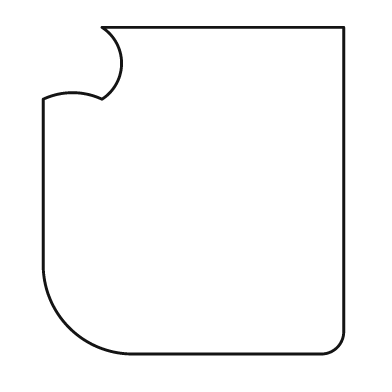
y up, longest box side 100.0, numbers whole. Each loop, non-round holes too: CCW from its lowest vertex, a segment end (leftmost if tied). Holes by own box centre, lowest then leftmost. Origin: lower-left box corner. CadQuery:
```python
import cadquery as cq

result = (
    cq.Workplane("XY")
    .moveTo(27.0, 0.0)
    .lineTo(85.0, 0.0)
    .threePointArc((90.0, 2.0), (92.0, 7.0))
    .lineTo(92.0, 100.0)
    .lineTo(18.0, 100.0)
    .threePointArc((24.0, 89.0), (18.0, 78.0))
    .threePointArc((9.0, 80.0), (0.0, 78.0))
    .lineTo(0.0, 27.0)
    .threePointArc((8.0, 8.0), (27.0, 0.0))
    .close()
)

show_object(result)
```